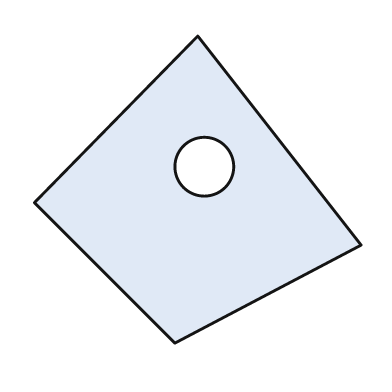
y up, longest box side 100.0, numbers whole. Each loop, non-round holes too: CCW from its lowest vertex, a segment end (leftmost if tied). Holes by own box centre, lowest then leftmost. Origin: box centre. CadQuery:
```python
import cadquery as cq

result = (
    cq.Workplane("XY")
    .moveTo(-7.0, -47.0)
    .lineTo(50.0, -17.0)
    .lineTo(0.0, 47.0)
    .lineTo(-50.0, -4.0)
    .close()
    .moveTo(2.0, 7.0)
    .circle(9.0)
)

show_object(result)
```